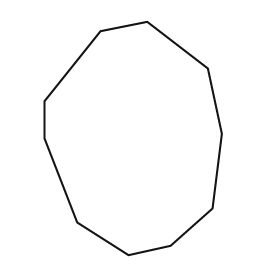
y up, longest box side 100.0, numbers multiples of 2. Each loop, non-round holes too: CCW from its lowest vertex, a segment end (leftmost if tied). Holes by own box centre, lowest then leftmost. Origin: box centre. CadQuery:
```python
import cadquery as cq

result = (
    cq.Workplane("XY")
    .moveTo(-2.0, -50.0)
    .lineTo(16.0, -46.0)
    .lineTo(34.0, -30.0)
    .lineTo(38.0, 2.0)
    .lineTo(32.0, 30.0)
    .lineTo(6.0, 50.0)
    .lineTo(-14.0, 46.0)
    .lineTo(-38.0, 16.0)
    .lineTo(-38.0, 0.0)
    .lineTo(-24.0, -36.0)
    .close()
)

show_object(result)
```